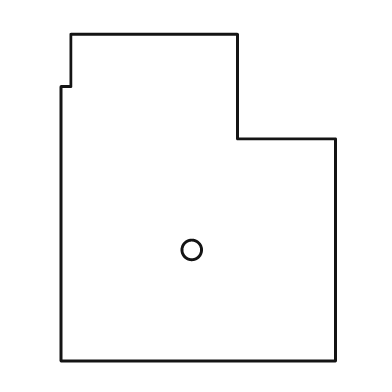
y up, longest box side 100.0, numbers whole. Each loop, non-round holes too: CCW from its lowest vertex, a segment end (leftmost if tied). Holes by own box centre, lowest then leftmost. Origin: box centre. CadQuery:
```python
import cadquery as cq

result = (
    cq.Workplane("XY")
    .moveTo(-42.0, -50.0)
    .lineTo(42.0, -50.0)
    .lineTo(42.0, 18.0)
    .lineTo(12.0, 18.0)
    .lineTo(12.0, 50.0)
    .lineTo(-39.0, 50.0)
    .lineTo(-39.0, 34.0)
    .lineTo(-42.0, 34.0)
    .close()
    .moveTo(-2.0, -16.0)
    .circle(3.0)
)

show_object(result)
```